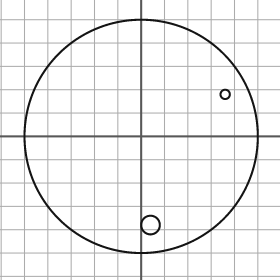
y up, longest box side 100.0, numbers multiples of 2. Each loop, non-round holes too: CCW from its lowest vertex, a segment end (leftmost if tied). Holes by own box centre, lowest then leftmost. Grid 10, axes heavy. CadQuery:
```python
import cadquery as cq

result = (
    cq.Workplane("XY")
    .moveTo(0.0, 0.0)
    .circle(50.0)
    .moveTo(4.0, -38.0)
    .circle(4.0)
    .moveTo(36.0, 18.0)
    .circle(2.0)
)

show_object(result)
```